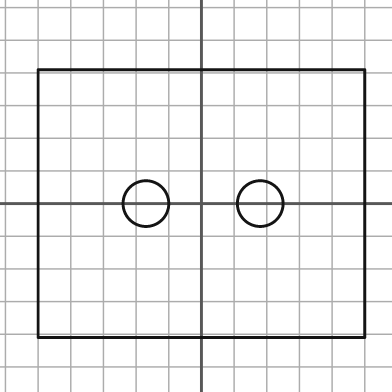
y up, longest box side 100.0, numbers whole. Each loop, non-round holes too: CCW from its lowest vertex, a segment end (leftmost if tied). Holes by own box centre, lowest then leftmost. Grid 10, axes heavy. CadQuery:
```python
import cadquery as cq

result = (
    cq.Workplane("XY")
    .moveTo(-50.0, -41.0)
    .lineTo(50.0, -41.0)
    .lineTo(50.0, 41.0)
    .lineTo(-50.0, 41.0)
    .close()
    .moveTo(-17.0, 0.0)
    .circle(7.0)
    .moveTo(18.0, 0.0)
    .circle(7.0)
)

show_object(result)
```